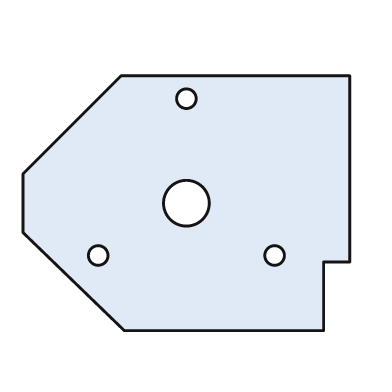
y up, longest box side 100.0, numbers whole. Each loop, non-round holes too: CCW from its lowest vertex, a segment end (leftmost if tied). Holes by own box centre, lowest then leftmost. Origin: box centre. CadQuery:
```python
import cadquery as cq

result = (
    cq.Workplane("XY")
    .moveTo(-19.0, -39.0)
    .lineTo(42.0, -39.0)
    .lineTo(42.0, -18.0)
    .lineTo(50.0, -18.0)
    .lineTo(50.0, 39.0)
    .lineTo(-20.0, 39.0)
    .lineTo(-50.0, 9.0)
    .lineTo(-50.0, -9.0)
    .close()
    .moveTo(-27.0, -16.0)
    .circle(3.0)
    .moveTo(27.0, -16.0)
    .circle(3.0)
    .moveTo(0.0, 0.0)
    .circle(7.0)
    .moveTo(0.0, 32.0)
    .circle(3.0)
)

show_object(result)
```